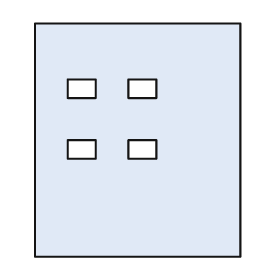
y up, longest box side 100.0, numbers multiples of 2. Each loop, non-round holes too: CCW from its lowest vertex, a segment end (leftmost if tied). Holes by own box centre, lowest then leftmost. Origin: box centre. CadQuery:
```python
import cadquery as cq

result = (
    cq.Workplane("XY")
    .moveTo(-44.0, -50.0)
    .lineTo(44.0, -50.0)
    .lineTo(44.0, 50.0)
    .lineTo(-44.0, 50.0)
    .close()
    .moveTo(-30.0, -8.0)
    .lineTo(-18.0, -8.0)
    .lineTo(-18.0, 0.0)
    .lineTo(-30.0, 0.0)
    .close()
    .moveTo(-4.0, -8.0)
    .lineTo(8.0, -8.0)
    .lineTo(8.0, 0.0)
    .lineTo(-4.0, 0.0)
    .close()
    .moveTo(-30.0, 18.0)
    .lineTo(-18.0, 18.0)
    .lineTo(-18.0, 26.0)
    .lineTo(-30.0, 26.0)
    .close()
    .moveTo(-4.0, 18.0)
    .lineTo(8.0, 18.0)
    .lineTo(8.0, 26.0)
    .lineTo(-4.0, 26.0)
    .close()
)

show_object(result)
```